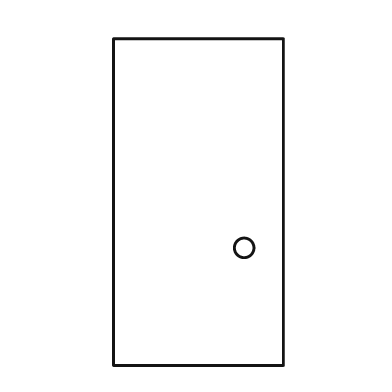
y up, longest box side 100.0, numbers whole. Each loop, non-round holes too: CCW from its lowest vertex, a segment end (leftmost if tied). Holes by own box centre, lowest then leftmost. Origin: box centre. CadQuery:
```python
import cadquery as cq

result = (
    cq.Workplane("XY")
    .moveTo(-26.0, -50.0)
    .lineTo(26.0, -50.0)
    .lineTo(26.0, 50.0)
    .lineTo(-26.0, 50.0)
    .close()
    .moveTo(14.0, -14.0)
    .circle(3.0)
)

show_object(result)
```